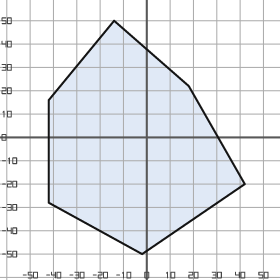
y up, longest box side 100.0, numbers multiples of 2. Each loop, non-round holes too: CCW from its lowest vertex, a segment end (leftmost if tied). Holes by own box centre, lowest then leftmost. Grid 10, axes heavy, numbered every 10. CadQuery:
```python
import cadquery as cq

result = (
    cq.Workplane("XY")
    .moveTo(-2.0, -50.0)
    .lineTo(42.0, -20.0)
    .lineTo(18.0, 22.0)
    .lineTo(-14.0, 50.0)
    .lineTo(-42.0, 16.0)
    .lineTo(-42.0, -28.0)
    .close()
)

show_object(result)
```